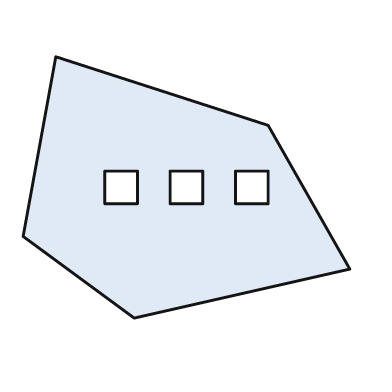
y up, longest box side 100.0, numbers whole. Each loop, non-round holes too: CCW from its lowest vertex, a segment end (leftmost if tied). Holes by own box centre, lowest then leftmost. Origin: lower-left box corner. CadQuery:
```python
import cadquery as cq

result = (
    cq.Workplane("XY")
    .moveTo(34.0, 0.0)
    .lineTo(100.0, 15.0)
    .lineTo(75.0, 59.0)
    .lineTo(10.0, 80.0)
    .lineTo(0.0, 25.0)
    .close()
    .moveTo(25.0, 35.0)
    .lineTo(35.0, 35.0)
    .lineTo(35.0, 45.0)
    .lineTo(25.0, 45.0)
    .close()
    .moveTo(45.0, 35.0)
    .lineTo(55.0, 35.0)
    .lineTo(55.0, 45.0)
    .lineTo(45.0, 45.0)
    .close()
    .moveTo(65.0, 35.0)
    .lineTo(75.0, 35.0)
    .lineTo(75.0, 45.0)
    .lineTo(65.0, 45.0)
    .close()
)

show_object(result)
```